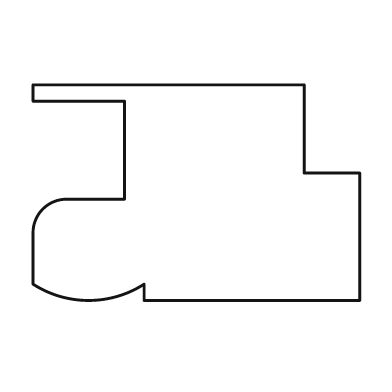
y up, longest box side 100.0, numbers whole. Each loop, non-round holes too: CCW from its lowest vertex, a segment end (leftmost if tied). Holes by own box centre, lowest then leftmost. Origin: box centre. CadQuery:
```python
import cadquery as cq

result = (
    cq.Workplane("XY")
    .moveTo(-16.0, -33.0)
    .lineTo(50.0, -33.0)
    .lineTo(50.0, 6.0)
    .lineTo(33.0, 6.0)
    .lineTo(33.0, 33.0)
    .lineTo(-50.0, 33.0)
    .lineTo(-50.0, 28.0)
    .lineTo(-22.0, 28.0)
    .lineTo(-22.0, -2.0)
    .lineTo(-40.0, -2.0)
    .threePointArc((-47.0, -5.0), (-50.0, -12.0))
    .lineTo(-50.0, -28.0)
    .threePointArc((-33.0, -33.0), (-16.0, -28.0))
    .close()
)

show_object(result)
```